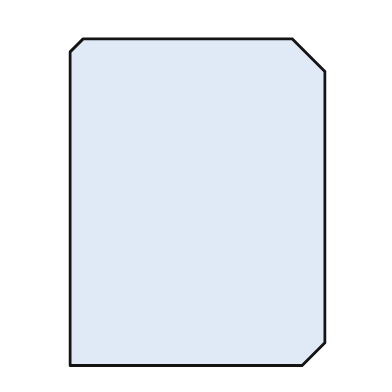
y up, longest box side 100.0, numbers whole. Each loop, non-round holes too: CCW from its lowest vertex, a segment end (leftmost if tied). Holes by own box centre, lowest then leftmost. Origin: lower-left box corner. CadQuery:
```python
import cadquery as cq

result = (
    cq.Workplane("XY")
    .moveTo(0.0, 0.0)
    .lineTo(71.0, 0.0)
    .lineTo(78.0, 7.0)
    .lineTo(78.0, 90.0)
    .lineTo(68.0, 100.0)
    .lineTo(4.0, 100.0)
    .lineTo(0.0, 96.0)
    .close()
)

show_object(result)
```